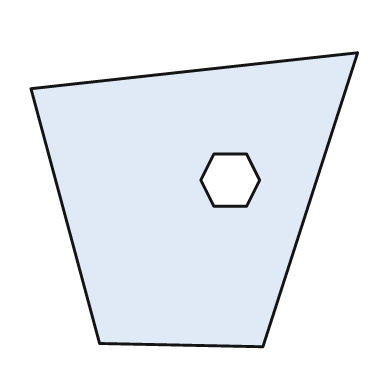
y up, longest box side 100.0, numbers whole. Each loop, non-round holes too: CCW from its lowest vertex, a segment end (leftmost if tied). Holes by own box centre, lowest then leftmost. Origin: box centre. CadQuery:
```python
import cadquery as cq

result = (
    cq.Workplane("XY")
    .moveTo(21.0, -45.0)
    .lineTo(50.0, 45.0)
    .lineTo(-50.0, 34.0)
    .lineTo(-29.0, -44.0)
    .close()
    .moveTo(6.0, -2.0)
    .lineTo(16.0, -2.0)
    .lineTo(20.0, 6.0)
    .lineTo(16.0, 14.0)
    .lineTo(6.0, 14.0)
    .lineTo(2.0, 6.0)
    .close()
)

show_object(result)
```